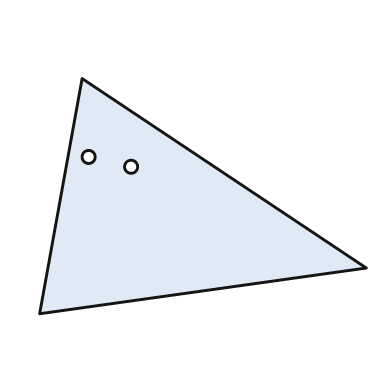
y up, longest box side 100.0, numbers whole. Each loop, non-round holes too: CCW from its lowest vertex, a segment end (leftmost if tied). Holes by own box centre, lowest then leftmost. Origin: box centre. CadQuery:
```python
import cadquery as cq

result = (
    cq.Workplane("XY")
    .moveTo(-50.0, -36.0)
    .lineTo(50.0, -22.0)
    .lineTo(-37.0, 36.0)
    .close()
    .moveTo(-22.0, 9.0)
    .circle(2.0)
    .moveTo(-35.0, 12.0)
    .circle(2.0)
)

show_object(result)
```